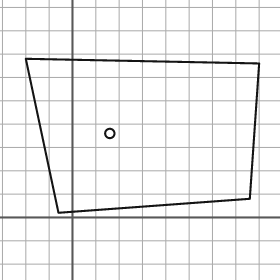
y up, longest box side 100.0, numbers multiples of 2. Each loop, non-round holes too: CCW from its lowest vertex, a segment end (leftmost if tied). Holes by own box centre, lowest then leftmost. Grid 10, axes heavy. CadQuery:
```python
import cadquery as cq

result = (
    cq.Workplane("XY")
    .moveTo(-6.0, 2.0)
    .lineTo(76.0, 8.0)
    .lineTo(80.0, 66.0)
    .lineTo(-20.0, 68.0)
    .close()
    .moveTo(16.0, 36.0)
    .circle(2.0)
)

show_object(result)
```